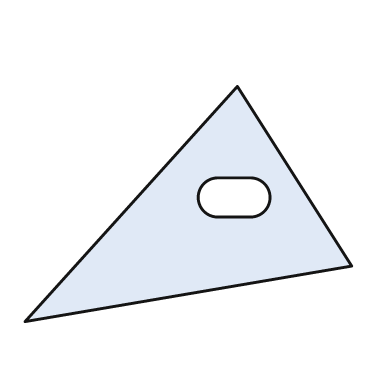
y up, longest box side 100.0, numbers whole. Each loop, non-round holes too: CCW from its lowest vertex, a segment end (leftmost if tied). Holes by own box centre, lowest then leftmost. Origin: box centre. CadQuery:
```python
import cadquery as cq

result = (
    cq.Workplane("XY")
    .moveTo(-50.0, -36.0)
    .lineTo(50.0, -19.0)
    .lineTo(15.0, 36.0)
    .close()
    .moveTo(9.0, -4.0)
    .lineTo(19.0, -4.0)
    .threePointArc((25.0, 2.0), (19.0, 8.0))
    .lineTo(9.0, 8.0)
    .threePointArc((3.0, 2.0), (9.0, -4.0))
    .close()
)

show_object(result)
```